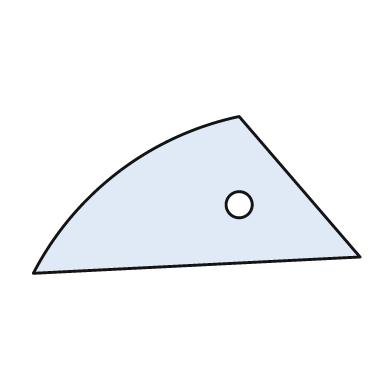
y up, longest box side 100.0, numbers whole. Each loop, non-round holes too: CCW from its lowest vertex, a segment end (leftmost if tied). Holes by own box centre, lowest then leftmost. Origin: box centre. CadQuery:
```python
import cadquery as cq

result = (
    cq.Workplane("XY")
    .moveTo(-50.0, -24.0)
    .lineTo(50.0, -19.0)
    .lineTo(13.0, 24.0)
    .threePointArc((-24.0, 7.0), (-50.0, -24.0))
    .close()
    .moveTo(13.0, -3.0)
    .circle(4.0)
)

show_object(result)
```